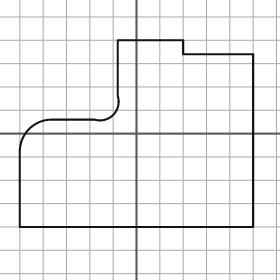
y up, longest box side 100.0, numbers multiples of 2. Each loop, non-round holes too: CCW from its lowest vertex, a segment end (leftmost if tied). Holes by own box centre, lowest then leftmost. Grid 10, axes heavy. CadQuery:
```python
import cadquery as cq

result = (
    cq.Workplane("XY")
    .moveTo(-50.0, -40.0)
    .lineTo(50.0, -40.0)
    .lineTo(50.0, 34.0)
    .lineTo(20.0, 34.0)
    .lineTo(20.0, 40.0)
    .lineTo(-8.0, 40.0)
    .lineTo(-8.0, 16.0)
    .threePointArc((-10.0, 8.0), (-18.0, 6.0))
    .lineTo(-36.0, 6.0)
    .threePointArc((-46.0, 2.0), (-50.0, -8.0))
    .close()
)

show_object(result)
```